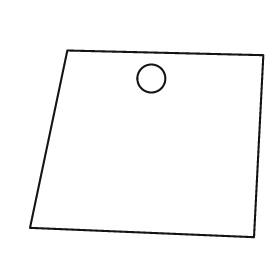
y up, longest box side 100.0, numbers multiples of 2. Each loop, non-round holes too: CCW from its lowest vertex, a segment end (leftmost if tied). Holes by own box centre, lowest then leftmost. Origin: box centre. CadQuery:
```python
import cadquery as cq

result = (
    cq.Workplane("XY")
    .moveTo(46.0, -40.0)
    .lineTo(50.0, 38.0)
    .lineTo(-34.0, 40.0)
    .lineTo(-50.0, -36.0)
    .close()
    .moveTo(2.0, 28.0)
    .circle(6.0)
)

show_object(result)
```